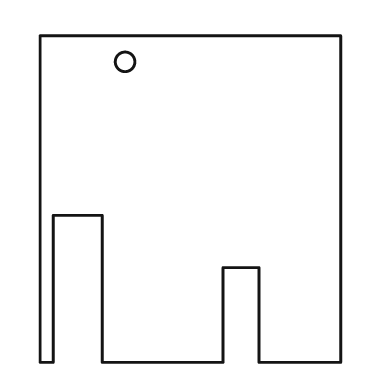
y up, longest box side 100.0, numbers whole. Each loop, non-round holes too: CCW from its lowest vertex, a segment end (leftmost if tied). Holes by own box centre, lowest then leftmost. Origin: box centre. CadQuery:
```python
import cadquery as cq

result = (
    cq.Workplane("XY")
    .moveTo(-46.0, -50.0)
    .lineTo(-42.0, -50.0)
    .lineTo(-42.0, -5.0)
    .lineTo(-27.0, -5.0)
    .lineTo(-27.0, -50.0)
    .lineTo(10.0, -50.0)
    .lineTo(10.0, -21.0)
    .lineTo(21.0, -21.0)
    .lineTo(21.0, -50.0)
    .lineTo(46.0, -50.0)
    .lineTo(46.0, 50.0)
    .lineTo(-46.0, 50.0)
    .close()
    .moveTo(-20.0, 42.0)
    .circle(3.0)
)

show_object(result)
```